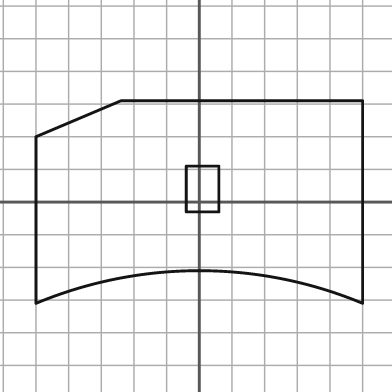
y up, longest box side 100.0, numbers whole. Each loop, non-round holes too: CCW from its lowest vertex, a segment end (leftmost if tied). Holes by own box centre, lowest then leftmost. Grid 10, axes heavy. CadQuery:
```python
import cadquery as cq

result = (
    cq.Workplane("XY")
    .moveTo(-50.0, -31.0)
    .threePointArc((0.0, -21.0), (50.0, -31.0))
    .lineTo(50.0, 31.0)
    .lineTo(-24.0, 31.0)
    .lineTo(-50.0, 20.0)
    .close()
    .moveTo(-4.0, -3.0)
    .lineTo(6.0, -3.0)
    .lineTo(6.0, 11.0)
    .lineTo(-4.0, 11.0)
    .close()
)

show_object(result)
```